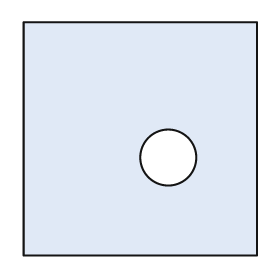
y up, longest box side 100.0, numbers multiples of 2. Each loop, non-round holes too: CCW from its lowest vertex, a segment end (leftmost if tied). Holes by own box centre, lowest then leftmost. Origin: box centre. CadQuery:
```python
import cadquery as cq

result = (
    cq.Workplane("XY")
    .moveTo(-50.0, -50.0)
    .lineTo(50.0, -50.0)
    .lineTo(50.0, 50.0)
    .lineTo(-50.0, 50.0)
    .close()
    .moveTo(12.0, -8.0)
    .circle(12.0)
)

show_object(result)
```